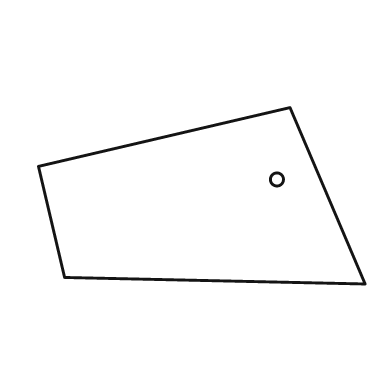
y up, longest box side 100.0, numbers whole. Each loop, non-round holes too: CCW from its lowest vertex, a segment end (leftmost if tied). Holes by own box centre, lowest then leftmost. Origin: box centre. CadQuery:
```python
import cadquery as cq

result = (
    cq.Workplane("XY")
    .moveTo(50.0, -27.0)
    .lineTo(27.0, 27.0)
    .lineTo(-50.0, 9.0)
    .lineTo(-42.0, -25.0)
    .close()
    .moveTo(23.0, 5.0)
    .circle(2.0)
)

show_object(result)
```